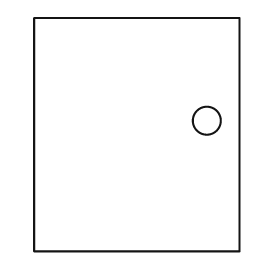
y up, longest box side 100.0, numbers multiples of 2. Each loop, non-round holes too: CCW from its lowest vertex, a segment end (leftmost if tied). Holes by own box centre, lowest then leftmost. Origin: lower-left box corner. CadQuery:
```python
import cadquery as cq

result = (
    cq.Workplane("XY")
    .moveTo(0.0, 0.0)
    .lineTo(88.0, 0.0)
    .lineTo(88.0, 100.0)
    .lineTo(0.0, 100.0)
    .close()
    .moveTo(74.0, 56.0)
    .circle(6.0)
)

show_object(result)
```